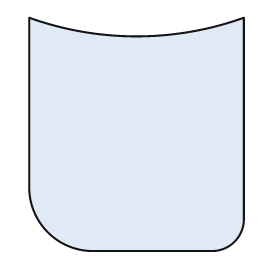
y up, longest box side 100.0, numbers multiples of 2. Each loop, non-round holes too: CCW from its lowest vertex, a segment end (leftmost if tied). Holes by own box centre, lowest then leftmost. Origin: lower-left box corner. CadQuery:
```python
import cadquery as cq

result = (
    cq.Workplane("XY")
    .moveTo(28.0, 0.0)
    .lineTo(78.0, 0.0)
    .threePointArc((88.0, 4.0), (92.0, 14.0))
    .lineTo(92.0, 100.0)
    .threePointArc((46.0, 92.0), (0.0, 100.0))
    .lineTo(0.0, 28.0)
    .threePointArc((8.0, 8.0), (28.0, 0.0))
    .close()
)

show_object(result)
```